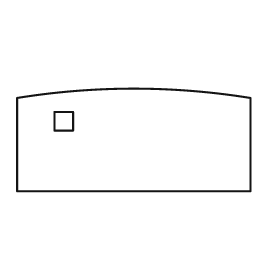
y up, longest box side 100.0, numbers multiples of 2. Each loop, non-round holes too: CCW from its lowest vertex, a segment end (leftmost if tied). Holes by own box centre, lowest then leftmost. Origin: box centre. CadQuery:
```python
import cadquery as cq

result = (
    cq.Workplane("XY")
    .moveTo(-50.0, -22.0)
    .lineTo(50.0, -22.0)
    .lineTo(50.0, 18.0)
    .threePointArc((0.0, 22.0), (-50.0, 18.0))
    .close()
    .moveTo(-34.0, 4.0)
    .lineTo(-26.0, 4.0)
    .lineTo(-26.0, 12.0)
    .lineTo(-34.0, 12.0)
    .close()
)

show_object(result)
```